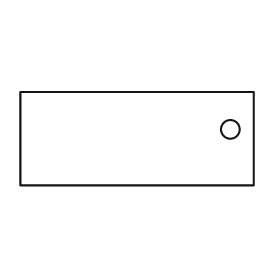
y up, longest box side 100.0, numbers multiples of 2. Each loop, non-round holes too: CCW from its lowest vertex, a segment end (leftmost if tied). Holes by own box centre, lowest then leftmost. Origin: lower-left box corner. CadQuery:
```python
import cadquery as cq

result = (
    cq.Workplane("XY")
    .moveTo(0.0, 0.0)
    .lineTo(100.0, 0.0)
    .lineTo(100.0, 40.0)
    .lineTo(0.0, 40.0)
    .close()
    .moveTo(90.0, 24.0)
    .circle(4.0)
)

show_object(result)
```